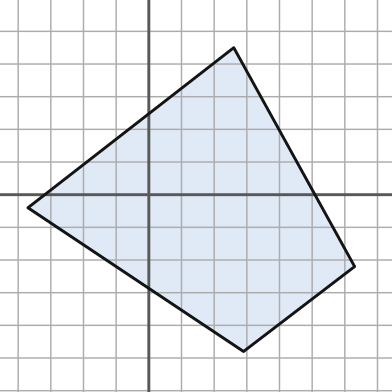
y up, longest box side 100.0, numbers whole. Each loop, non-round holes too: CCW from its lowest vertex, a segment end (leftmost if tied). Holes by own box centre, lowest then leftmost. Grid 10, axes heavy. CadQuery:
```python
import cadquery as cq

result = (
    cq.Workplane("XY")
    .moveTo(29.0, -48.0)
    .lineTo(63.0, -22.0)
    .lineTo(26.0, 45.0)
    .lineTo(-37.0, -4.0)
    .close()
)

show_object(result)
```